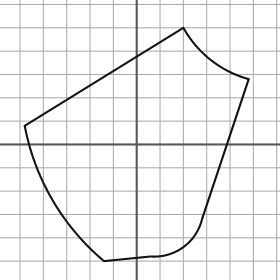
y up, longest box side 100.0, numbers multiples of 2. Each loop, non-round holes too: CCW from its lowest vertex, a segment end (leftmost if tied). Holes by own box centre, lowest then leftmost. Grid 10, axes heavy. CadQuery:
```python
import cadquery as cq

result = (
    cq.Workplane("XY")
    .moveTo(-14.0, -50.0)
    .lineTo(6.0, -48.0)
    .threePointArc((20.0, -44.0), (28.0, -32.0))
    .lineTo(48.0, 28.0)
    .threePointArc((32.0, 36.0), (20.0, 50.0))
    .lineTo(-48.0, 8.0)
    .threePointArc((-36.0, -24.0), (-14.0, -50.0))
    .close()
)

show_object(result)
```